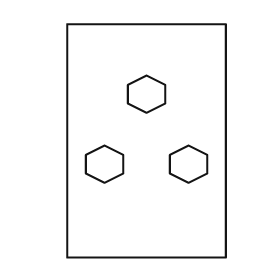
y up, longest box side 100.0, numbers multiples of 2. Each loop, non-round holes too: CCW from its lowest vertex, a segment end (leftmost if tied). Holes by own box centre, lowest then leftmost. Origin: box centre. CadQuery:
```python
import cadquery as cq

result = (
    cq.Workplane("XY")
    .moveTo(-34.0, -50.0)
    .lineTo(34.0, -50.0)
    .lineTo(34.0, 50.0)
    .lineTo(-34.0, 50.0)
    .close()
    .moveTo(-18.0, -18.0)
    .lineTo(-10.0, -14.0)
    .lineTo(-10.0, -6.0)
    .lineTo(-18.0, -2.0)
    .lineTo(-26.0, -6.0)
    .lineTo(-26.0, -14.0)
    .close()
    .moveTo(18.0, -18.0)
    .lineTo(26.0, -14.0)
    .lineTo(26.0, -6.0)
    .lineTo(18.0, -2.0)
    .lineTo(10.0, -6.0)
    .lineTo(10.0, -14.0)
    .close()
    .moveTo(0.0, 12.0)
    .lineTo(8.0, 16.0)
    .lineTo(8.0, 24.0)
    .lineTo(0.0, 28.0)
    .lineTo(-8.0, 24.0)
    .lineTo(-8.0, 16.0)
    .close()
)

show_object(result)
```